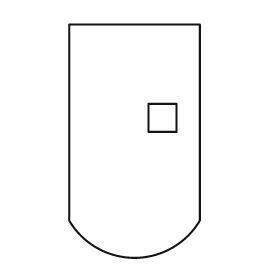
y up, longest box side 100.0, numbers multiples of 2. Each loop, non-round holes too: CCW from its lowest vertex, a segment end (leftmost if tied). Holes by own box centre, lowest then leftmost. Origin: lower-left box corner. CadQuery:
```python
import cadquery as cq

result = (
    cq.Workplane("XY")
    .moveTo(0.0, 16.0)
    .threePointArc((28.0, 0.0), (56.0, 16.0))
    .lineTo(56.0, 100.0)
    .lineTo(0.0, 100.0)
    .close()
    .moveTo(34.0, 54.0)
    .lineTo(46.0, 54.0)
    .lineTo(46.0, 66.0)
    .lineTo(34.0, 66.0)
    .close()
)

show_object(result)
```